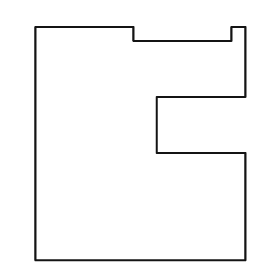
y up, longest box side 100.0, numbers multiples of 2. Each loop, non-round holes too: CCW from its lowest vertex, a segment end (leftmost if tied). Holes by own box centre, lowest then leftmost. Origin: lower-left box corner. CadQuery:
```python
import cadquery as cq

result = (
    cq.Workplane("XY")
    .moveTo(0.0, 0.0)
    .lineTo(90.0, 0.0)
    .lineTo(90.0, 46.0)
    .lineTo(52.0, 46.0)
    .lineTo(52.0, 70.0)
    .lineTo(90.0, 70.0)
    .lineTo(90.0, 100.0)
    .lineTo(84.0, 100.0)
    .lineTo(84.0, 94.0)
    .lineTo(42.0, 94.0)
    .lineTo(42.0, 100.0)
    .lineTo(0.0, 100.0)
    .close()
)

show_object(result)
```